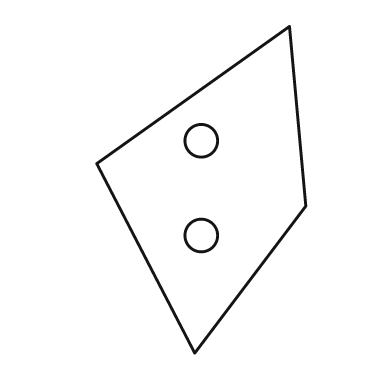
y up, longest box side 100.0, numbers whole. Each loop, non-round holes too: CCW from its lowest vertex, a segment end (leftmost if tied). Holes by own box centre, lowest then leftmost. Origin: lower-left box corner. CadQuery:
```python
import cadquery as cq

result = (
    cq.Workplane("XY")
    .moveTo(30.0, 0.0)
    .lineTo(64.0, 45.0)
    .lineTo(59.0, 100.0)
    .lineTo(0.0, 58.0)
    .close()
    .moveTo(32.0, 36.0)
    .circle(5.0)
    .moveTo(32.0, 65.0)
    .circle(5.0)
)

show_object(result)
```